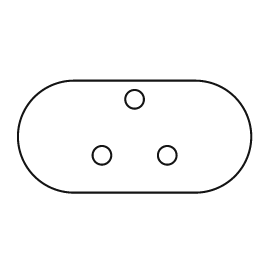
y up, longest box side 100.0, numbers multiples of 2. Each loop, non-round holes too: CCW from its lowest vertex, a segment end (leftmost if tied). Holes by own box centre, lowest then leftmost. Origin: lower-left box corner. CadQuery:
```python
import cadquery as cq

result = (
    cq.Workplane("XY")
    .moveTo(24.0, 0.0)
    .lineTo(76.0, 0.0)
    .threePointArc((100.0, 24.0), (76.0, 48.0))
    .lineTo(24.0, 48.0)
    .threePointArc((0.0, 24.0), (24.0, 0.0))
    .close()
    .moveTo(36.0, 16.0)
    .circle(4.0)
    .moveTo(64.0, 16.0)
    .circle(4.0)
    .moveTo(50.0, 40.0)
    .circle(4.0)
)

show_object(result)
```